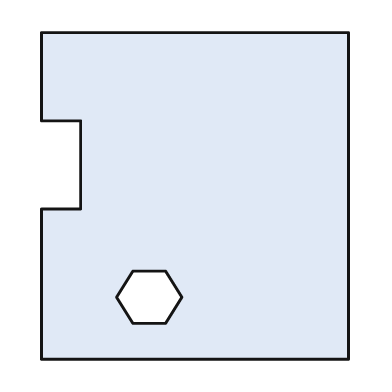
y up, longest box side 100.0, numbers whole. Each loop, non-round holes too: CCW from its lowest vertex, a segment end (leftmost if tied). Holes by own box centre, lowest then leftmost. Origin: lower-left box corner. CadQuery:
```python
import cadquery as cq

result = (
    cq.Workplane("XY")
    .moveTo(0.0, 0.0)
    .lineTo(94.0, 0.0)
    .lineTo(94.0, 100.0)
    .lineTo(0.0, 100.0)
    .lineTo(0.0, 73.0)
    .lineTo(12.0, 73.0)
    .lineTo(12.0, 46.0)
    .lineTo(0.0, 46.0)
    .close()
    .moveTo(28.0, 11.0)
    .lineTo(38.0, 11.0)
    .lineTo(43.0, 19.0)
    .lineTo(38.0, 27.0)
    .lineTo(28.0, 27.0)
    .lineTo(23.0, 19.0)
    .close()
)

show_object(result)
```